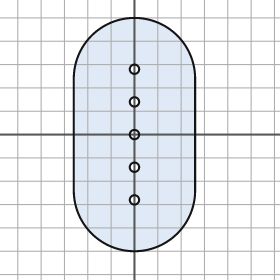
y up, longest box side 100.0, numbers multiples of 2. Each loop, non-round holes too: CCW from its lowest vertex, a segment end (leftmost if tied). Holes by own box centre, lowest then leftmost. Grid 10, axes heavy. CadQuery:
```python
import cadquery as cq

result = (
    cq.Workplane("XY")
    .moveTo(-26.0, -24.0)
    .threePointArc((0.0, -50.0), (26.0, -24.0))
    .lineTo(26.0, 24.0)
    .threePointArc((0.0, 50.0), (-26.0, 24.0))
    .close()
    .moveTo(0.0, -28.0)
    .circle(2.0)
    .moveTo(0.0, -14.0)
    .circle(2.0)
    .moveTo(0.0, 0.0)
    .circle(2.0)
    .moveTo(0.0, 14.0)
    .circle(2.0)
    .moveTo(0.0, 28.0)
    .circle(2.0)
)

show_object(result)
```